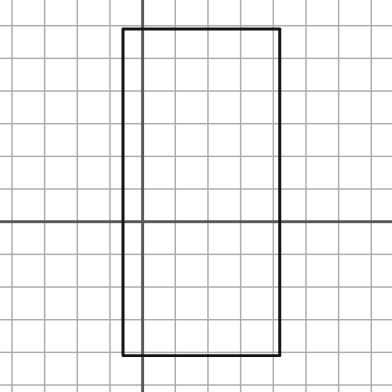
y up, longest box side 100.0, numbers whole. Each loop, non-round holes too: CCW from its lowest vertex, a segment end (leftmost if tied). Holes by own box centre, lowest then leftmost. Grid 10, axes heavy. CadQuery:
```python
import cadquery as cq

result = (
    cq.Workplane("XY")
    .moveTo(-6.0, -41.0)
    .lineTo(42.0, -41.0)
    .lineTo(42.0, 59.0)
    .lineTo(-6.0, 59.0)
    .close()
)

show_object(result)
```